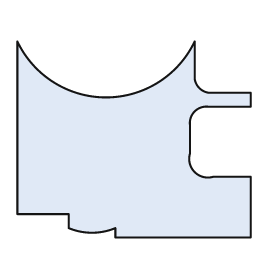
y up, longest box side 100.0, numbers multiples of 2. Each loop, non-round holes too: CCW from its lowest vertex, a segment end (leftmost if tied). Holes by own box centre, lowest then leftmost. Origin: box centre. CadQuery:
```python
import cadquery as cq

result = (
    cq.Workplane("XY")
    .moveTo(-8.0, -42.0)
    .lineTo(50.0, -42.0)
    .lineTo(50.0, -16.0)
    .lineTo(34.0, -16.0)
    .threePointArc((26.0, -14.0), (24.0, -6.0))
    .lineTo(24.0, 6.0)
    .threePointArc((26.0, 12.0), (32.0, 14.0))
    .lineTo(50.0, 14.0)
    .lineTo(50.0, 20.0)
    .lineTo(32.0, 20.0)
    .threePointArc((28.0, 22.0), (26.0, 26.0))
    .lineTo(26.0, 42.0)
    .threePointArc((-12.0, 18.0), (-50.0, 42.0))
    .lineTo(-50.0, -32.0)
    .lineTo(-28.0, -32.0)
    .lineTo(-28.0, -38.0)
    .threePointArc((-18.0, -40.0), (-8.0, -38.0))
    .close()
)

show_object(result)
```